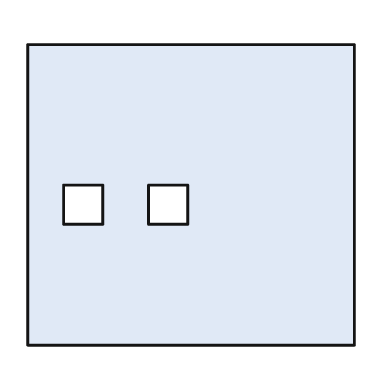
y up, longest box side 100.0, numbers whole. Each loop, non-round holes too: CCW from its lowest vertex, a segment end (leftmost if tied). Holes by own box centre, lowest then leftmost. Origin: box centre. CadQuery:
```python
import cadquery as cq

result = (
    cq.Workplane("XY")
    .moveTo(-50.0, -46.0)
    .lineTo(50.0, -46.0)
    .lineTo(50.0, 46.0)
    .lineTo(-50.0, 46.0)
    .close()
    .moveTo(-39.0, -9.0)
    .lineTo(-27.0, -9.0)
    .lineTo(-27.0, 3.0)
    .lineTo(-39.0, 3.0)
    .close()
    .moveTo(-13.0, -9.0)
    .lineTo(-1.0, -9.0)
    .lineTo(-1.0, 3.0)
    .lineTo(-13.0, 3.0)
    .close()
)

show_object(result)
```